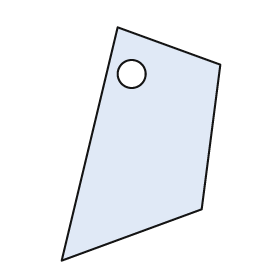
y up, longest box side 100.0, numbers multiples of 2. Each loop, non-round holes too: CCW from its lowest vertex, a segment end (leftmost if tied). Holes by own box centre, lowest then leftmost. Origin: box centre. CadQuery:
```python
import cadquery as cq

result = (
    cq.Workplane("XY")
    .moveTo(-34.0, -50.0)
    .lineTo(26.0, -28.0)
    .lineTo(34.0, 34.0)
    .lineTo(-10.0, 50.0)
    .close()
    .moveTo(-4.0, 30.0)
    .circle(6.0)
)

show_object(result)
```